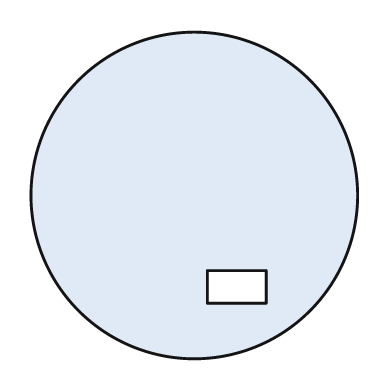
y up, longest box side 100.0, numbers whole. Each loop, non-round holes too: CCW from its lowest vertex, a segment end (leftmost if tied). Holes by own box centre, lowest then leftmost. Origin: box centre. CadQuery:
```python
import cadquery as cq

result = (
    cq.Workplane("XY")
    .moveTo(0.0, 0.0)
    .circle(50.0)
    .moveTo(4.0, -33.0)
    .lineTo(22.0, -33.0)
    .lineTo(22.0, -23.0)
    .lineTo(4.0, -23.0)
    .close()
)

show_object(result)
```